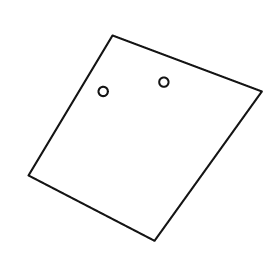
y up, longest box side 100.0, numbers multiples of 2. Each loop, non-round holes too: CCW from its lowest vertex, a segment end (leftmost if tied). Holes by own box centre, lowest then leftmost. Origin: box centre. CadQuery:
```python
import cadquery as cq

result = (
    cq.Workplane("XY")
    .moveTo(4.0, -44.0)
    .lineTo(50.0, 20.0)
    .lineTo(-14.0, 44.0)
    .lineTo(-50.0, -16.0)
    .close()
    .moveTo(-18.0, 20.0)
    .circle(2.0)
    .moveTo(8.0, 24.0)
    .circle(2.0)
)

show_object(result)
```